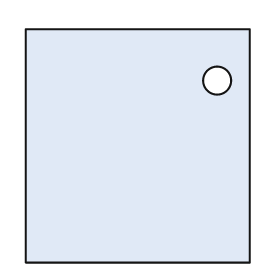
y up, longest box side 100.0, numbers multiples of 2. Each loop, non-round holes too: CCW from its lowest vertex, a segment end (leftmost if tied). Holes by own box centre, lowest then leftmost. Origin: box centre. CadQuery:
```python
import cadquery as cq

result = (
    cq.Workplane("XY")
    .moveTo(-48.0, -50.0)
    .lineTo(48.0, -50.0)
    .lineTo(48.0, 50.0)
    .lineTo(-48.0, 50.0)
    .close()
    .moveTo(34.0, 28.0)
    .circle(6.0)
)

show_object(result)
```